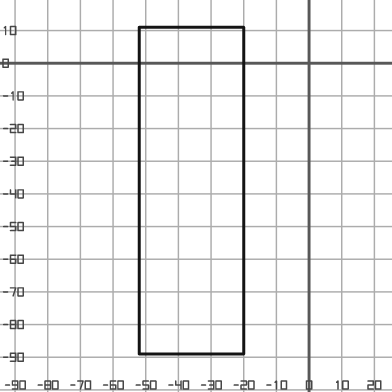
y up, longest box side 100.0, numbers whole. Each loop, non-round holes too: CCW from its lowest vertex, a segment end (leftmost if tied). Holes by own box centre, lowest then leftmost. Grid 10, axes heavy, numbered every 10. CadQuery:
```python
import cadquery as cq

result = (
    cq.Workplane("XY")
    .moveTo(-52.0, -89.0)
    .lineTo(-20.0, -89.0)
    .lineTo(-20.0, 11.0)
    .lineTo(-52.0, 11.0)
    .close()
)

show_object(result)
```